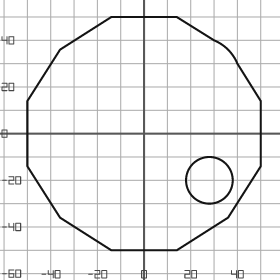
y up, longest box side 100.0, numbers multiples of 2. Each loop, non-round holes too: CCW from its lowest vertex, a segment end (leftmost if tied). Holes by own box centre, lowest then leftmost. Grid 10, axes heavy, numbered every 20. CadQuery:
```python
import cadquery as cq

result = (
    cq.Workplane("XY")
    .moveTo(-14.0, -50.0)
    .lineTo(14.0, -50.0)
    .lineTo(36.0, -36.0)
    .lineTo(50.0, -14.0)
    .lineTo(50.0, 14.0)
    .lineTo(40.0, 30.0)
    .threePointArc((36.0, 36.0), (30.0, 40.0))
    .lineTo(14.0, 50.0)
    .lineTo(-14.0, 50.0)
    .lineTo(-36.0, 36.0)
    .lineTo(-50.0, 14.0)
    .lineTo(-50.0, -14.0)
    .lineTo(-36.0, -36.0)
    .close()
    .moveTo(28.0, -20.0)
    .circle(10.0)
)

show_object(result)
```